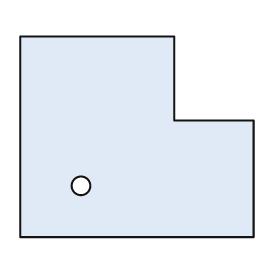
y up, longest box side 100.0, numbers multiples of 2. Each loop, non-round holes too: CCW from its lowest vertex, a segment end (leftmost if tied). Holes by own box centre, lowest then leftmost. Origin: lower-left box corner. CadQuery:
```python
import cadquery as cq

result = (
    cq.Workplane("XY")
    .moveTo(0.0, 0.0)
    .lineTo(100.0, 0.0)
    .lineTo(100.0, 50.0)
    .lineTo(66.0, 50.0)
    .lineTo(66.0, 86.0)
    .lineTo(0.0, 86.0)
    .close()
    .moveTo(26.0, 22.0)
    .circle(4.0)
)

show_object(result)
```